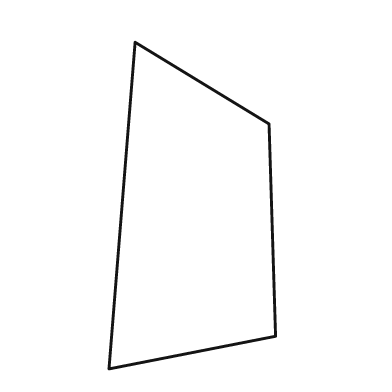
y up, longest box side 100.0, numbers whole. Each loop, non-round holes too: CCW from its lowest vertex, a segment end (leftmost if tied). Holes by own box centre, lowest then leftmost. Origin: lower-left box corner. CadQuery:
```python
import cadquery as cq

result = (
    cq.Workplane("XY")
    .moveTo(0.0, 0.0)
    .lineTo(51.0, 10.0)
    .lineTo(49.0, 75.0)
    .lineTo(8.0, 100.0)
    .close()
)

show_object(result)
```